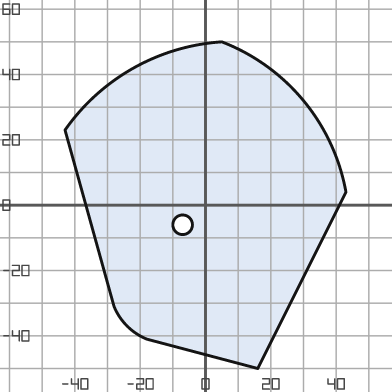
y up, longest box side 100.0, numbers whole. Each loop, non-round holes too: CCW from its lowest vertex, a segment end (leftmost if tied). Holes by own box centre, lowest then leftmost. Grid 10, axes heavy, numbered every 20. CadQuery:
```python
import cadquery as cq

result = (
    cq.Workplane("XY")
    .moveTo(16.0, -50.0)
    .lineTo(43.0, 4.0)
    .threePointArc((30.0, 32.0), (5.0, 50.0))
    .threePointArc((-22.0, 42.0), (-43.0, 23.0))
    .lineTo(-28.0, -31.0)
    .threePointArc((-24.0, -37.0), (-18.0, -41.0))
    .close()
    .moveTo(-7.0, -6.0)
    .circle(3.0)
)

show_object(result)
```